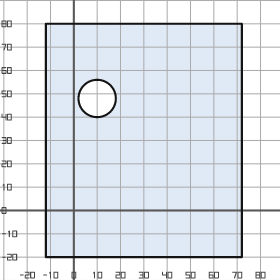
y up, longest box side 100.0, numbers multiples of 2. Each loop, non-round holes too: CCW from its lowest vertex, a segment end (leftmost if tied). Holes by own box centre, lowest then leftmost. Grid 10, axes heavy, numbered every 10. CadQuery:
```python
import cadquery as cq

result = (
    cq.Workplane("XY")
    .moveTo(-12.0, -20.0)
    .lineTo(72.0, -20.0)
    .lineTo(72.0, 80.0)
    .lineTo(-12.0, 80.0)
    .close()
    .moveTo(10.0, 48.0)
    .circle(8.0)
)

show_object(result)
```